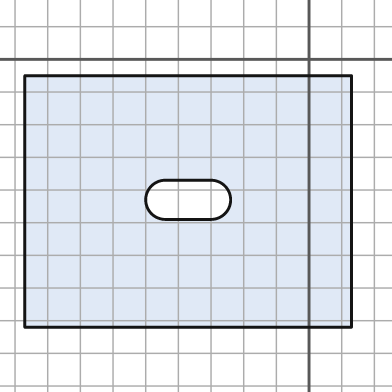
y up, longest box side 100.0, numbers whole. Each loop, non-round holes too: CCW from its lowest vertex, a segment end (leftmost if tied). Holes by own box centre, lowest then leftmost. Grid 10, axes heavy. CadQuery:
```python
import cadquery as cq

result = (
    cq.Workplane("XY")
    .moveTo(-87.0, -82.0)
    .lineTo(13.0, -82.0)
    .lineTo(13.0, -5.0)
    .lineTo(-87.0, -5.0)
    .close()
    .moveTo(-44.0, -49.0)
    .lineTo(-30.0, -49.0)
    .threePointArc((-24.0, -43.0), (-30.0, -37.0))
    .lineTo(-44.0, -37.0)
    .threePointArc((-50.0, -43.0), (-44.0, -49.0))
    .close()
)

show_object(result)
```